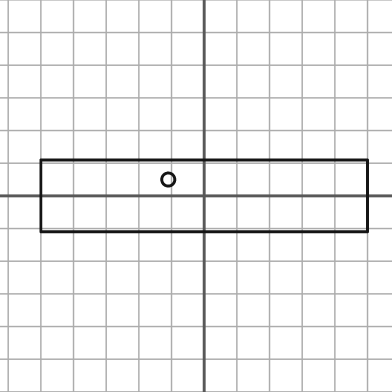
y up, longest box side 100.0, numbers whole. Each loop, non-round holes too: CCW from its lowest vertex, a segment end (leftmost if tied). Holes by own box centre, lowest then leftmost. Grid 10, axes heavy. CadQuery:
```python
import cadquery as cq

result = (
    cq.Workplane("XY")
    .moveTo(-50.0, -11.0)
    .lineTo(50.0, -11.0)
    .lineTo(50.0, 11.0)
    .lineTo(-50.0, 11.0)
    .close()
    .moveTo(-11.0, 5.0)
    .circle(2.0)
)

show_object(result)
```